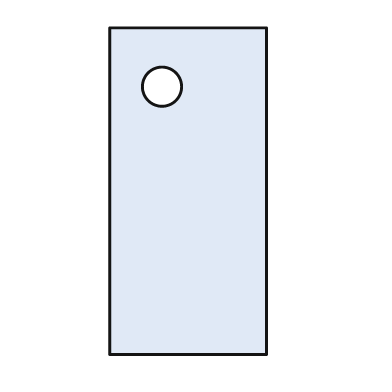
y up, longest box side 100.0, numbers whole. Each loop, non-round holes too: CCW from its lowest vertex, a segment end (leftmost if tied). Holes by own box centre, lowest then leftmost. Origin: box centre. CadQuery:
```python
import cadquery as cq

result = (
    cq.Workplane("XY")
    .moveTo(-24.0, -50.0)
    .lineTo(24.0, -50.0)
    .lineTo(24.0, 50.0)
    .lineTo(-24.0, 50.0)
    .close()
    .moveTo(-8.0, 32.0)
    .circle(6.0)
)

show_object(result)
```